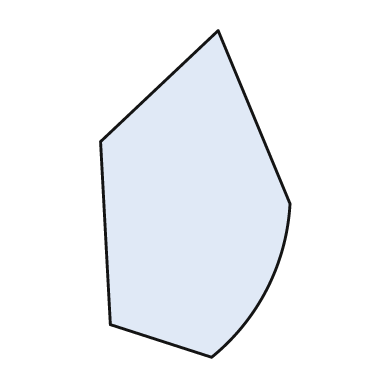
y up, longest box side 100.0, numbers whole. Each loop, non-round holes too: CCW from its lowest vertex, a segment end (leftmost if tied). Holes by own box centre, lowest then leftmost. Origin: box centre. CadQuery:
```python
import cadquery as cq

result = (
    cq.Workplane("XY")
    .moveTo(5.0, -50.0)
    .threePointArc((22.0, -29.0), (29.0, -3.0))
    .lineTo(7.0, 50.0)
    .lineTo(-29.0, 16.0)
    .lineTo(-26.0, -40.0)
    .close()
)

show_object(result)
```